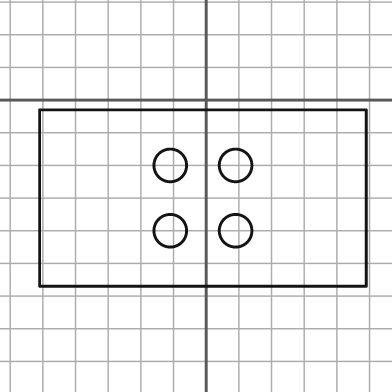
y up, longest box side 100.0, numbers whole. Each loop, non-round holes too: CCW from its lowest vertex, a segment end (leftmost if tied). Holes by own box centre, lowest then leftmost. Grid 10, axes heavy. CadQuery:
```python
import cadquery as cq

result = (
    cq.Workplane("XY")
    .moveTo(-51.0, -57.0)
    .lineTo(49.0, -57.0)
    .lineTo(49.0, -3.0)
    .lineTo(-51.0, -3.0)
    .close()
    .moveTo(-11.0, -40.0)
    .circle(5.0)
    .moveTo(9.0, -40.0)
    .circle(5.0)
    .moveTo(-11.0, -20.0)
    .circle(5.0)
    .moveTo(9.0, -20.0)
    .circle(5.0)
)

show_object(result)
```